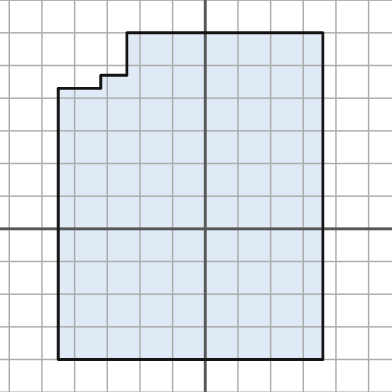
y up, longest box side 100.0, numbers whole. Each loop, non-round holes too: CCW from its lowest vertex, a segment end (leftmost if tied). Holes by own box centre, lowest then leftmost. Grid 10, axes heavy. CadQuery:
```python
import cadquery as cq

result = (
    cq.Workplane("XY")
    .moveTo(-45.0, -40.0)
    .lineTo(36.0, -40.0)
    .lineTo(36.0, 60.0)
    .lineTo(-24.0, 60.0)
    .lineTo(-24.0, 47.0)
    .lineTo(-32.0, 47.0)
    .lineTo(-32.0, 43.0)
    .lineTo(-45.0, 43.0)
    .close()
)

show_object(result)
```